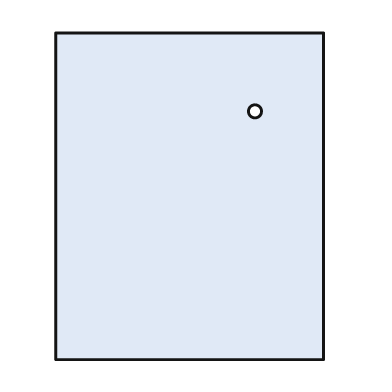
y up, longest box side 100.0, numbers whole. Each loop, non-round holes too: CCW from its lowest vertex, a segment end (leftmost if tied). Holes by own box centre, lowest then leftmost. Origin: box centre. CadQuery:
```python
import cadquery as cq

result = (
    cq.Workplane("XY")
    .moveTo(-41.0, -50.0)
    .lineTo(41.0, -50.0)
    .lineTo(41.0, 50.0)
    .lineTo(-41.0, 50.0)
    .close()
    .moveTo(20.0, 26.0)
    .circle(2.0)
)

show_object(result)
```